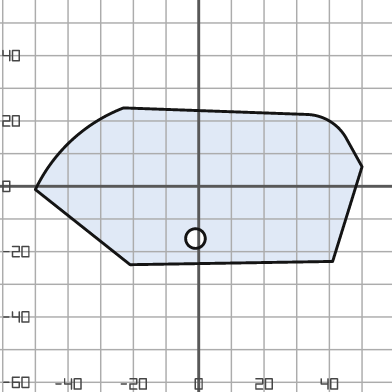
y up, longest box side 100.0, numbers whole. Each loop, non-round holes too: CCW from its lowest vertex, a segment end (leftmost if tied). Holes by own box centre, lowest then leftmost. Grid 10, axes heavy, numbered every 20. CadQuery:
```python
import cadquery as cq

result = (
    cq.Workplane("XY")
    .moveTo(-21.0, -24.0)
    .lineTo(41.0, -23.0)
    .lineTo(50.0, 6.0)
    .lineTo(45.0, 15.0)
    .threePointArc((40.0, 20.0), (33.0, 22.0))
    .lineTo(-23.0, 24.0)
    .threePointArc((-39.0, 14.0), (-50.0, -1.0))
    .close()
    .moveTo(-1.0, -16.0)
    .circle(3.0)
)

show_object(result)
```